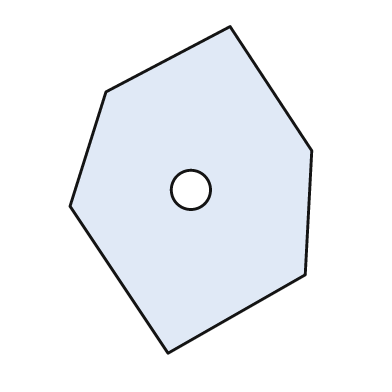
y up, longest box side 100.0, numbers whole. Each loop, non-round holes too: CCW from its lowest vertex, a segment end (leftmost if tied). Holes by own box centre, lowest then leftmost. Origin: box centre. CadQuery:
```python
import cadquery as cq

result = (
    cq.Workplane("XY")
    .moveTo(-7.0, -50.0)
    .lineTo(35.0, -26.0)
    .lineTo(37.0, 12.0)
    .lineTo(12.0, 50.0)
    .lineTo(-26.0, 30.0)
    .lineTo(-37.0, -5.0)
    .close()
    .moveTo(0.0, 0.0)
    .circle(6.0)
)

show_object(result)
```